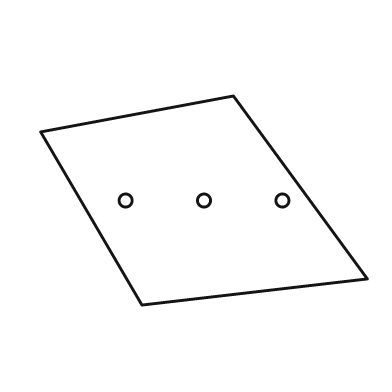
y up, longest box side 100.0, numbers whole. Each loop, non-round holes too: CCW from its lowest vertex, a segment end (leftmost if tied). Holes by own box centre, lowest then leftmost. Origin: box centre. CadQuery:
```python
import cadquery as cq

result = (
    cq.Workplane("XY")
    .moveTo(-19.0, -32.0)
    .lineTo(50.0, -24.0)
    .lineTo(9.0, 32.0)
    .lineTo(-50.0, 21.0)
    .close()
    .moveTo(-24.0, 0.0)
    .circle(2.0)
    .moveTo(0.0, 0.0)
    .circle(2.0)
    .moveTo(24.0, 0.0)
    .circle(2.0)
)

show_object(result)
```